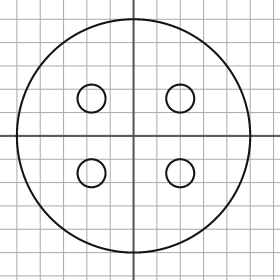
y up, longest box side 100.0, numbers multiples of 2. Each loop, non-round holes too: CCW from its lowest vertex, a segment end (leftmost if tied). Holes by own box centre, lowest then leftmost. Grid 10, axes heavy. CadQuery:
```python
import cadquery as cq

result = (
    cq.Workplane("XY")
    .moveTo(0.0, 0.0)
    .circle(50.0)
    .moveTo(-18.0, -16.0)
    .circle(6.0)
    .moveTo(20.0, -16.0)
    .circle(6.0)
    .moveTo(-18.0, 16.0)
    .circle(6.0)
    .moveTo(20.0, 16.0)
    .circle(6.0)
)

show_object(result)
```